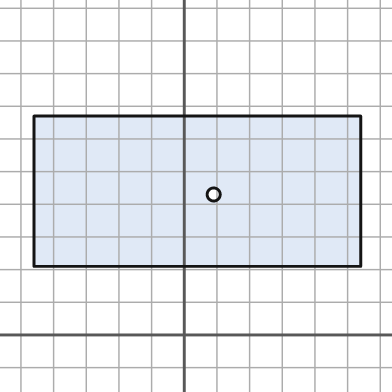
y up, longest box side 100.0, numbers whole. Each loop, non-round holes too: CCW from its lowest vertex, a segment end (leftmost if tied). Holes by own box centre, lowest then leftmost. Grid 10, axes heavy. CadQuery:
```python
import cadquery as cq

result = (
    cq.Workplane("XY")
    .moveTo(-46.0, 21.0)
    .lineTo(54.0, 21.0)
    .lineTo(54.0, 67.0)
    .lineTo(-46.0, 67.0)
    .close()
    .moveTo(9.0, 43.0)
    .circle(2.0)
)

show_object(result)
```